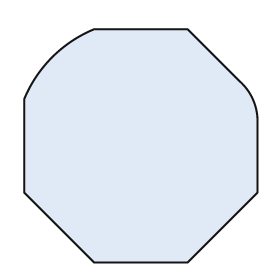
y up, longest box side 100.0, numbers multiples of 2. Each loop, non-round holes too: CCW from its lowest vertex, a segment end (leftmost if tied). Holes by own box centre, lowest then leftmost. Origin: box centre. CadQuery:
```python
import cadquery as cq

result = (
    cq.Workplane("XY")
    .moveTo(-20.0, -50.0)
    .lineTo(20.0, -50.0)
    .lineTo(50.0, -20.0)
    .lineTo(50.0, 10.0)
    .threePointArc((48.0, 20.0), (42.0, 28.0))
    .lineTo(20.0, 50.0)
    .lineTo(-20.0, 50.0)
    .threePointArc((-38.0, 38.0), (-50.0, 20.0))
    .lineTo(-50.0, -20.0)
    .close()
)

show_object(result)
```